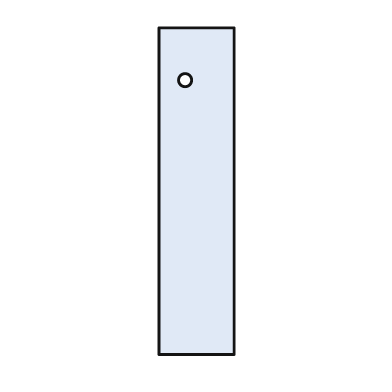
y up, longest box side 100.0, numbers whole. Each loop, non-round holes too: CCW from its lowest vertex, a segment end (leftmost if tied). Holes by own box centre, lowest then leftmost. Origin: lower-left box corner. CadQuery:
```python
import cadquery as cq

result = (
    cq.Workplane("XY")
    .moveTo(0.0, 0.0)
    .lineTo(23.0, 0.0)
    .lineTo(23.0, 100.0)
    .lineTo(0.0, 100.0)
    .close()
    .moveTo(8.0, 84.0)
    .circle(2.0)
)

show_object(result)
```